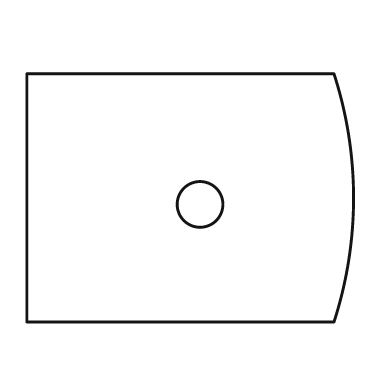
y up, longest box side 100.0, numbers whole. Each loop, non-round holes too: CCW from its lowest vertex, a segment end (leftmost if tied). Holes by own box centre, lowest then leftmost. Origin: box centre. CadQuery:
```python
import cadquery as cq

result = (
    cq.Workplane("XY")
    .moveTo(-50.0, -38.0)
    .lineTo(44.0, -38.0)
    .threePointArc((50.0, 0.0), (44.0, 38.0))
    .lineTo(-50.0, 38.0)
    .close()
    .moveTo(3.0, -2.0)
    .circle(7.0)
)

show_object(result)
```